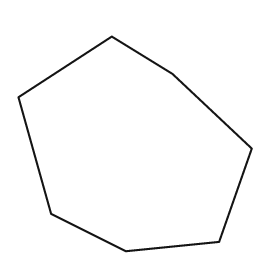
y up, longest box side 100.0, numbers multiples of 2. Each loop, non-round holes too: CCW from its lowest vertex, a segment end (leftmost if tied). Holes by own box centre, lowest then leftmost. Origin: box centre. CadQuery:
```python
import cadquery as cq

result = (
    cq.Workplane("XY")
    .moveTo(-4.0, -46.0)
    .lineTo(36.0, -42.0)
    .lineTo(50.0, -2.0)
    .lineTo(16.0, 30.0)
    .lineTo(-10.0, 46.0)
    .lineTo(-50.0, 20.0)
    .lineTo(-36.0, -30.0)
    .close()
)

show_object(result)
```